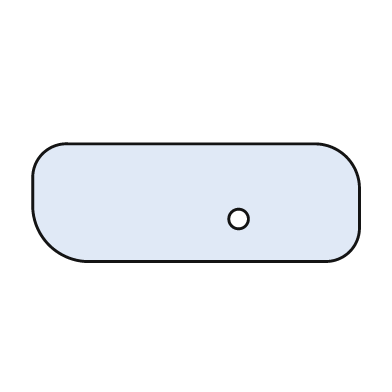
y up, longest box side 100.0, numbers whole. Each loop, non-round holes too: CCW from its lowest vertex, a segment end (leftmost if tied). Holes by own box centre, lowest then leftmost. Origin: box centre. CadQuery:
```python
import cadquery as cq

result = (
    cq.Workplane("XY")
    .moveTo(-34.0, -18.0)
    .lineTo(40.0, -18.0)
    .threePointArc((47.0, -15.0), (50.0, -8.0))
    .lineTo(50.0, 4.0)
    .threePointArc((46.0, 14.0), (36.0, 18.0))
    .lineTo(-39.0, 18.0)
    .threePointArc((-47.0, 15.0), (-50.0, 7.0))
    .lineTo(-50.0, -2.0)
    .threePointArc((-45.0, -13.0), (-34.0, -18.0))
    .close()
    .moveTo(13.0, -5.0)
    .circle(3.0)
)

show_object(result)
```